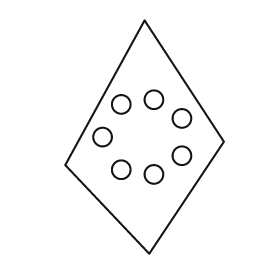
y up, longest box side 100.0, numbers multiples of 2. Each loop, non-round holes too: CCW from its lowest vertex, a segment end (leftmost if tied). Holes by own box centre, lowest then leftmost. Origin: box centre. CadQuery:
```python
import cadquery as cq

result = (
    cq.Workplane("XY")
    .moveTo(2.0, -50.0)
    .lineTo(34.0, -2.0)
    .lineTo(0.0, 50.0)
    .lineTo(-34.0, -12.0)
    .close()
    .moveTo(4.0, -16.0)
    .circle(4.0)
    .moveTo(-10.0, -14.0)
    .circle(4.0)
    .moveTo(16.0, -8.0)
    .circle(4.0)
    .moveTo(-18.0, 0.0)
    .circle(4.0)
    .moveTo(16.0, 8.0)
    .circle(4.0)
    .moveTo(-10.0, 14.0)
    .circle(4.0)
    .moveTo(4.0, 16.0)
    .circle(4.0)
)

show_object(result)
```